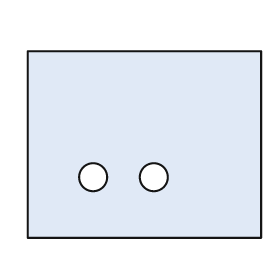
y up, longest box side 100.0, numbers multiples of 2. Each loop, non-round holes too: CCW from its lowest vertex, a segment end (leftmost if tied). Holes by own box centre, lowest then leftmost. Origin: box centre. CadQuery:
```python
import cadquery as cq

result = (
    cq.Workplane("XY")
    .moveTo(-50.0, -40.0)
    .lineTo(50.0, -40.0)
    .lineTo(50.0, 40.0)
    .lineTo(-50.0, 40.0)
    .close()
    .moveTo(-22.0, -14.0)
    .circle(6.0)
    .moveTo(4.0, -14.0)
    .circle(6.0)
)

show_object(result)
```